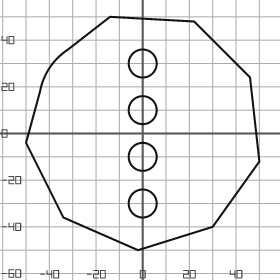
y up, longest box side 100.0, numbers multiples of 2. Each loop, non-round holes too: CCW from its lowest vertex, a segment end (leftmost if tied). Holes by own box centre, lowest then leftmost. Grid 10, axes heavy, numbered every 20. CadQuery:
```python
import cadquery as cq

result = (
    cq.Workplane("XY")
    .moveTo(-2.0, -50.0)
    .lineTo(30.0, -40.0)
    .lineTo(50.0, -12.0)
    .lineTo(46.0, 24.0)
    .lineTo(22.0, 48.0)
    .lineTo(-14.0, 50.0)
    .lineTo(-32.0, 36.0)
    .threePointArc((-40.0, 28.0), (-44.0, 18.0))
    .lineTo(-50.0, -4.0)
    .lineTo(-34.0, -36.0)
    .close()
    .moveTo(0.0, -30.0)
    .circle(6.0)
    .moveTo(0.0, -10.0)
    .circle(6.0)
    .moveTo(0.0, 10.0)
    .circle(6.0)
    .moveTo(0.0, 30.0)
    .circle(6.0)
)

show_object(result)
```